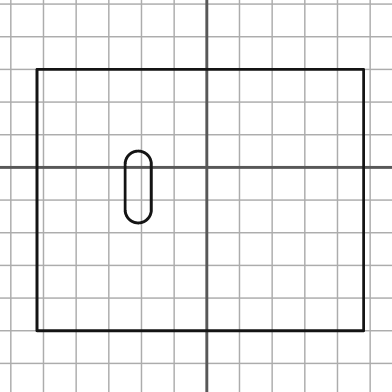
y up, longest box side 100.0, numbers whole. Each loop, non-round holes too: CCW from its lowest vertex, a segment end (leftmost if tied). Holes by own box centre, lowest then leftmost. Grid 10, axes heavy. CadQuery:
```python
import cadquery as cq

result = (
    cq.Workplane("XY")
    .moveTo(-52.0, -50.0)
    .lineTo(48.0, -50.0)
    .lineTo(48.0, 30.0)
    .lineTo(-52.0, 30.0)
    .close()
    .moveTo(-25.0, -13.0)
    .threePointArc((-21.0, -17.0), (-17.0, -13.0))
    .lineTo(-17.0, 1.0)
    .threePointArc((-21.0, 5.0), (-25.0, 1.0))
    .close()
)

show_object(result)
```